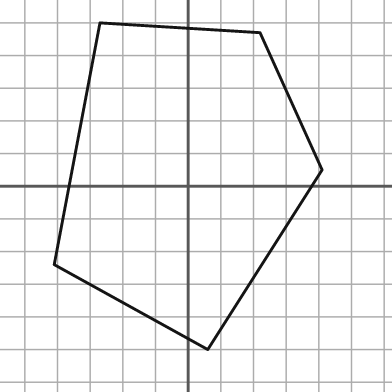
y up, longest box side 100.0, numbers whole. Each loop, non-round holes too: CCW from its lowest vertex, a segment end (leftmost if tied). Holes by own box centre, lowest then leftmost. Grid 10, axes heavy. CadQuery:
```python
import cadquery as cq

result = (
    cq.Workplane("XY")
    .moveTo(6.0, -50.0)
    .lineTo(41.0, 5.0)
    .lineTo(22.0, 47.0)
    .lineTo(-27.0, 50.0)
    .lineTo(-41.0, -24.0)
    .close()
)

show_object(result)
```